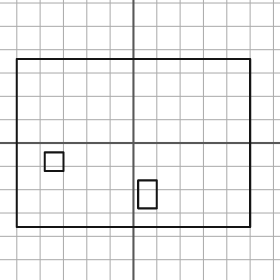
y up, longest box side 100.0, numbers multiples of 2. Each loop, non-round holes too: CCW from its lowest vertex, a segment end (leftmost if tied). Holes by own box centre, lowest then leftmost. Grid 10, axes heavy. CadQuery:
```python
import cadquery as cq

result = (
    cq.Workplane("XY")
    .moveTo(-50.0, -36.0)
    .lineTo(50.0, -36.0)
    .lineTo(50.0, 36.0)
    .lineTo(-50.0, 36.0)
    .close()
    .moveTo(2.0, -28.0)
    .lineTo(10.0, -28.0)
    .lineTo(10.0, -16.0)
    .lineTo(2.0, -16.0)
    .close()
    .moveTo(-38.0, -12.0)
    .lineTo(-30.0, -12.0)
    .lineTo(-30.0, -4.0)
    .lineTo(-38.0, -4.0)
    .close()
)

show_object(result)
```